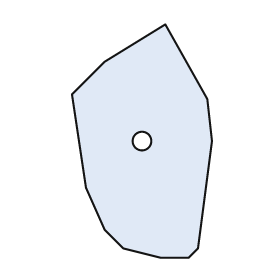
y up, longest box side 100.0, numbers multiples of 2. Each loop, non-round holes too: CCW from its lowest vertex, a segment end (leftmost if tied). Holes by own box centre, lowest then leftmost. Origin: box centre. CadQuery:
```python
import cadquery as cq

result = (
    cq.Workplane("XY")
    .moveTo(8.0, -50.0)
    .lineTo(20.0, -50.0)
    .lineTo(24.0, -46.0)
    .lineTo(30.0, 0.0)
    .lineTo(28.0, 18.0)
    .lineTo(10.0, 50.0)
    .lineTo(-16.0, 34.0)
    .lineTo(-30.0, 20.0)
    .lineTo(-24.0, -20.0)
    .lineTo(-16.0, -38.0)
    .lineTo(-8.0, -46.0)
    .close()
    .moveTo(0.0, 0.0)
    .circle(4.0)
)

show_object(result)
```